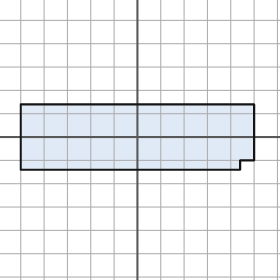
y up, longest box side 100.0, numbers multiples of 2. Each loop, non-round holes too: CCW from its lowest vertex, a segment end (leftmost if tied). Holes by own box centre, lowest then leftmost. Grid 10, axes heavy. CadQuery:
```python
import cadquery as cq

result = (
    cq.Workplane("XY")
    .moveTo(-50.0, -14.0)
    .lineTo(44.0, -14.0)
    .lineTo(44.0, -10.0)
    .lineTo(50.0, -10.0)
    .lineTo(50.0, 14.0)
    .lineTo(-50.0, 14.0)
    .close()
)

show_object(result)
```